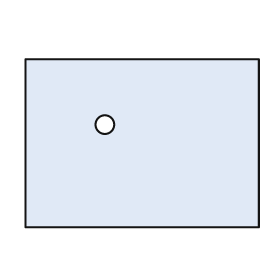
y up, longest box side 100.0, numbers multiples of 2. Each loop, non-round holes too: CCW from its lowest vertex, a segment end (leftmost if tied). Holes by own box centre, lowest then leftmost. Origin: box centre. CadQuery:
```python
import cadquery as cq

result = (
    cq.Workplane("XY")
    .moveTo(-50.0, -36.0)
    .lineTo(50.0, -36.0)
    .lineTo(50.0, 36.0)
    .lineTo(-50.0, 36.0)
    .close()
    .moveTo(-16.0, 8.0)
    .circle(4.0)
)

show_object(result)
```